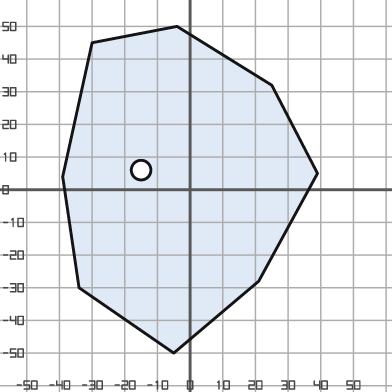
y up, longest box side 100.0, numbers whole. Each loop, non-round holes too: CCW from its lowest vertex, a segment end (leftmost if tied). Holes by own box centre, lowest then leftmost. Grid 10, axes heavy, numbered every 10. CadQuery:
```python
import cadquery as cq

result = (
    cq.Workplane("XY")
    .moveTo(-5.0, -50.0)
    .lineTo(21.0, -28.0)
    .lineTo(39.0, 5.0)
    .lineTo(25.0, 32.0)
    .lineTo(-4.0, 50.0)
    .lineTo(-30.0, 45.0)
    .lineTo(-39.0, 4.0)
    .lineTo(-34.0, -30.0)
    .close()
    .moveTo(-15.0, 6.0)
    .circle(3.0)
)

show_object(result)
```